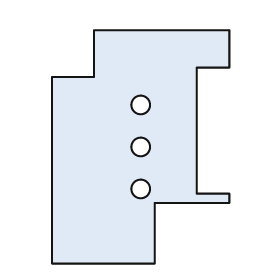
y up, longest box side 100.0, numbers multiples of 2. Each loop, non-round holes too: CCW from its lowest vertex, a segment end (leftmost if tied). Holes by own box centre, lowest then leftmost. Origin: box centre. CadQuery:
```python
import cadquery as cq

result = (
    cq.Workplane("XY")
    .moveTo(-38.0, -50.0)
    .lineTo(6.0, -50.0)
    .lineTo(6.0, -24.0)
    .lineTo(38.0, -24.0)
    .lineTo(38.0, -20.0)
    .lineTo(24.0, -20.0)
    .lineTo(24.0, 34.0)
    .lineTo(38.0, 34.0)
    .lineTo(38.0, 50.0)
    .lineTo(-20.0, 50.0)
    .lineTo(-20.0, 30.0)
    .lineTo(-38.0, 30.0)
    .close()
    .moveTo(0.0, -18.0)
    .circle(4.0)
    .moveTo(0.0, 0.0)
    .circle(4.0)
    .moveTo(0.0, 18.0)
    .circle(4.0)
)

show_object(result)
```